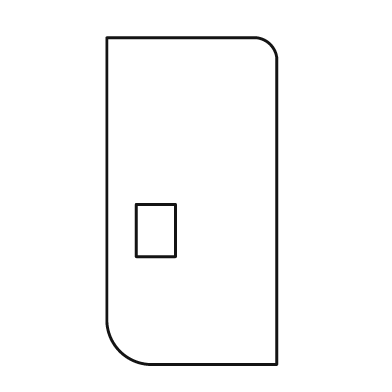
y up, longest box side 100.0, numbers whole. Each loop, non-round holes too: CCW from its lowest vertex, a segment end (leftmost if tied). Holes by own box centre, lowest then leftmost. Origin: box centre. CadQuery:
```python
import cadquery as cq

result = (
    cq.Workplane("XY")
    .moveTo(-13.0, -50.0)
    .lineTo(26.0, -50.0)
    .lineTo(26.0, 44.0)
    .threePointArc((24.0, 48.0), (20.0, 50.0))
    .lineTo(-26.0, 50.0)
    .lineTo(-26.0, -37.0)
    .threePointArc((-22.0, -46.0), (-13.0, -50.0))
    .close()
    .moveTo(-17.0, -17.0)
    .lineTo(-5.0, -17.0)
    .lineTo(-5.0, -1.0)
    .lineTo(-17.0, -1.0)
    .close()
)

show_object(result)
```